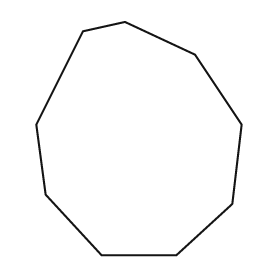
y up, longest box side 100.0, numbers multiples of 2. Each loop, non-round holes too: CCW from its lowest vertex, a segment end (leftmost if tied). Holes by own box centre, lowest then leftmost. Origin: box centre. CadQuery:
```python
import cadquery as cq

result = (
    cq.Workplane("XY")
    .moveTo(-16.0, -50.0)
    .lineTo(16.0, -50.0)
    .lineTo(40.0, -28.0)
    .lineTo(44.0, 6.0)
    .lineTo(24.0, 36.0)
    .lineTo(-6.0, 50.0)
    .lineTo(-24.0, 46.0)
    .lineTo(-44.0, 6.0)
    .lineTo(-40.0, -24.0)
    .close()
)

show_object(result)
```